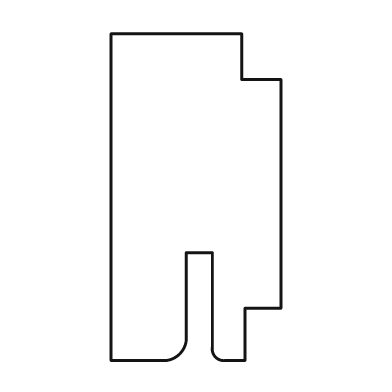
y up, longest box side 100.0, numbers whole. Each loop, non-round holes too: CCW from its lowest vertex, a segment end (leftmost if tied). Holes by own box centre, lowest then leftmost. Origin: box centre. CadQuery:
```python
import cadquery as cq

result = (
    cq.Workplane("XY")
    .moveTo(-26.0, -50.0)
    .lineTo(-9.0, -50.0)
    .threePointArc((-5.0, -48.0), (-3.0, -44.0))
    .lineTo(-3.0, -17.0)
    .lineTo(5.0, -17.0)
    .lineTo(5.0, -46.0)
    .threePointArc((6.0, -49.0), (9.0, -50.0))
    .lineTo(15.0, -50.0)
    .lineTo(15.0, -34.0)
    .lineTo(26.0, -34.0)
    .lineTo(26.0, 36.0)
    .lineTo(14.0, 36.0)
    .lineTo(14.0, 50.0)
    .lineTo(-26.0, 50.0)
    .close()
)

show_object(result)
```